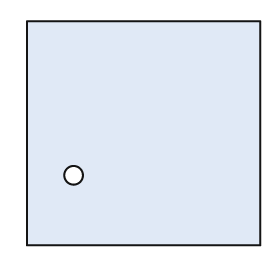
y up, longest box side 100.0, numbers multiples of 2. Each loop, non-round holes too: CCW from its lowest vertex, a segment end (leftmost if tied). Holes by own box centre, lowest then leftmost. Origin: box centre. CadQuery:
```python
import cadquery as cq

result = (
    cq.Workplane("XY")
    .moveTo(-50.0, -48.0)
    .lineTo(50.0, -48.0)
    .lineTo(50.0, 48.0)
    .lineTo(-50.0, 48.0)
    .close()
    .moveTo(-30.0, -18.0)
    .circle(4.0)
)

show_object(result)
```